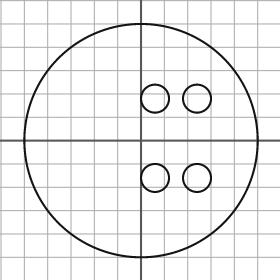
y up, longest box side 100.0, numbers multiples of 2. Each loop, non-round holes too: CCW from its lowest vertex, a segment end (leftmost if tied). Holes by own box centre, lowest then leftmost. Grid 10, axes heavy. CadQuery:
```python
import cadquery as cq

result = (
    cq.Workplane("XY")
    .moveTo(0.0, 0.0)
    .circle(50.0)
    .moveTo(6.0, -16.0)
    .circle(6.0)
    .moveTo(24.0, -16.0)
    .circle(6.0)
    .moveTo(6.0, 18.0)
    .circle(6.0)
    .moveTo(24.0, 18.0)
    .circle(6.0)
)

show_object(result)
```